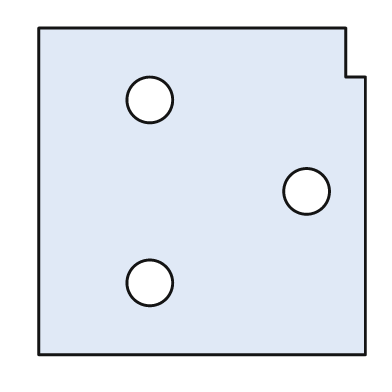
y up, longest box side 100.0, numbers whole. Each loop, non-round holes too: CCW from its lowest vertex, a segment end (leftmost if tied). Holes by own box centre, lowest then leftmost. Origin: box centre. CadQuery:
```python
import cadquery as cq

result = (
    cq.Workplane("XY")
    .moveTo(-50.0, -50.0)
    .lineTo(50.0, -50.0)
    .lineTo(50.0, 35.0)
    .lineTo(44.0, 35.0)
    .lineTo(44.0, 50.0)
    .lineTo(-50.0, 50.0)
    .close()
    .moveTo(-16.0, -28.0)
    .circle(7.0)
    .moveTo(32.0, 0.0)
    .circle(7.0)
    .moveTo(-16.0, 28.0)
    .circle(7.0)
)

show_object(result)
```